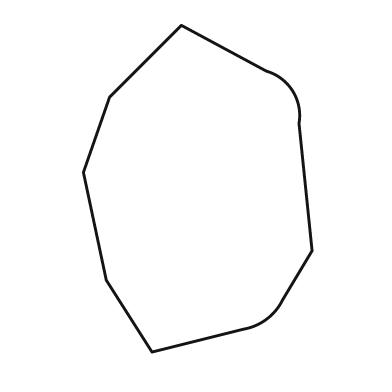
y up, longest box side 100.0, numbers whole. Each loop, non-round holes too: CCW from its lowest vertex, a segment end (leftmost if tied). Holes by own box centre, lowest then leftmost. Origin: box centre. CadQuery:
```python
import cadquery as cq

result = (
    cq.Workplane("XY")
    .moveTo(-14.0, -50.0)
    .lineTo(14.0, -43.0)
    .threePointArc((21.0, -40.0), (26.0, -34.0))
    .lineTo(35.0, -19.0)
    .lineTo(31.0, 20.0)
    .threePointArc((29.0, 30.0), (21.0, 36.0))
    .lineTo(-5.0, 50.0)
    .lineTo(-27.0, 28.0)
    .lineTo(-35.0, 5.0)
    .lineTo(-28.0, -28.0)
    .close()
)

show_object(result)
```